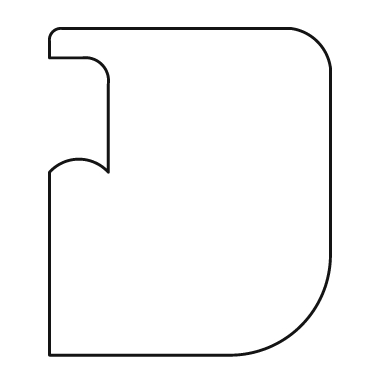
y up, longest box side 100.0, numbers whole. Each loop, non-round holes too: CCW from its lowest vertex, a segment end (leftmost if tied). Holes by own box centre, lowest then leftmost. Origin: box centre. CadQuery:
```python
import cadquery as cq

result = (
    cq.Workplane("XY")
    .moveTo(-43.0, -50.0)
    .lineTo(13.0, -50.0)
    .threePointArc((34.0, -41.0), (43.0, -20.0))
    .lineTo(43.0, 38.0)
    .threePointArc((39.0, 46.0), (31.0, 50.0))
    .lineTo(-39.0, 50.0)
    .threePointArc((-42.0, 49.0), (-43.0, 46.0))
    .lineTo(-43.0, 41.0)
    .lineTo(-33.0, 41.0)
    .threePointArc((-27.0, 39.0), (-25.0, 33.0))
    .lineTo(-25.0, 6.0)
    .threePointArc((-34.0, 10.0), (-43.0, 6.0))
    .close()
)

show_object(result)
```